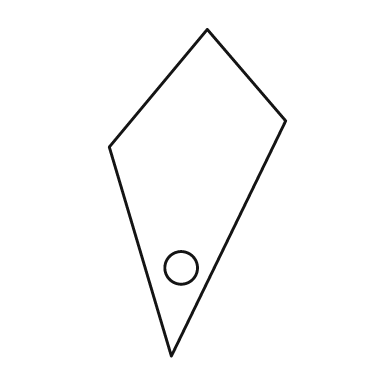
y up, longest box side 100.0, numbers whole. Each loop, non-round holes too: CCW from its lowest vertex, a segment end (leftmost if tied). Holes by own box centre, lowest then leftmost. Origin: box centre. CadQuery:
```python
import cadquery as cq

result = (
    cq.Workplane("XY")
    .moveTo(-8.0, -50.0)
    .lineTo(27.0, 22.0)
    .lineTo(3.0, 50.0)
    .lineTo(-27.0, 14.0)
    .close()
    .moveTo(-5.0, -23.0)
    .circle(5.0)
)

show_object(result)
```